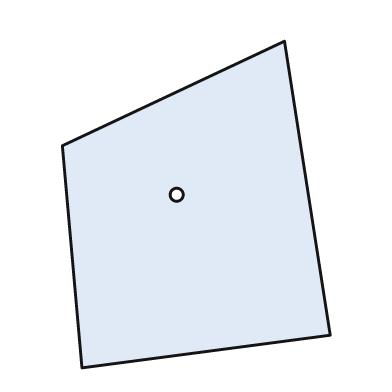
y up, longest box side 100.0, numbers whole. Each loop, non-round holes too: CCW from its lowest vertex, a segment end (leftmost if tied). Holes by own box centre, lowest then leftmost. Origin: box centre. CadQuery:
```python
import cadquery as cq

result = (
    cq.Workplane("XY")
    .moveTo(-35.0, -50.0)
    .lineTo(41.0, -40.0)
    .lineTo(27.0, 50.0)
    .lineTo(-41.0, 18.0)
    .close()
    .moveTo(-6.0, 3.0)
    .circle(2.0)
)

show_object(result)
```